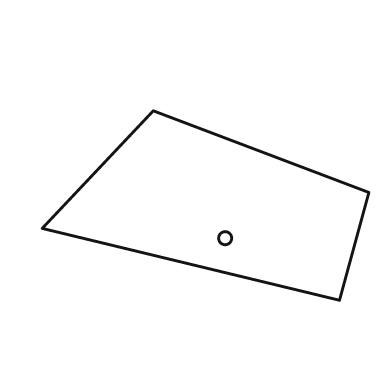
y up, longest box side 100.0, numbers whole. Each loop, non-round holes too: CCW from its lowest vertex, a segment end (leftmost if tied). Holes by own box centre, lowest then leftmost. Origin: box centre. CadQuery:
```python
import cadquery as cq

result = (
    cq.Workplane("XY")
    .moveTo(41.0, -29.0)
    .lineTo(50.0, 4.0)
    .lineTo(-16.0, 29.0)
    .lineTo(-50.0, -7.0)
    .close()
    .moveTo(6.0, -10.0)
    .circle(2.0)
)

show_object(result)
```